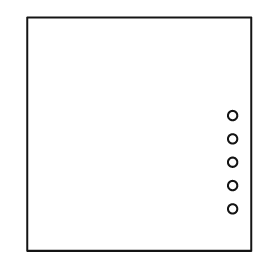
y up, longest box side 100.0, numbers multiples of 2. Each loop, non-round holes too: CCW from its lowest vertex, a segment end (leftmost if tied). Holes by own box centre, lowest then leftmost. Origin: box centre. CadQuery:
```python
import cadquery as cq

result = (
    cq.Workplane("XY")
    .moveTo(-48.0, -50.0)
    .lineTo(48.0, -50.0)
    .lineTo(48.0, 50.0)
    .lineTo(-48.0, 50.0)
    .close()
    .moveTo(40.0, -32.0)
    .circle(2.0)
    .moveTo(40.0, -22.0)
    .circle(2.0)
    .moveTo(40.0, -12.0)
    .circle(2.0)
    .moveTo(40.0, -2.0)
    .circle(2.0)
    .moveTo(40.0, 8.0)
    .circle(2.0)
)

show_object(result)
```